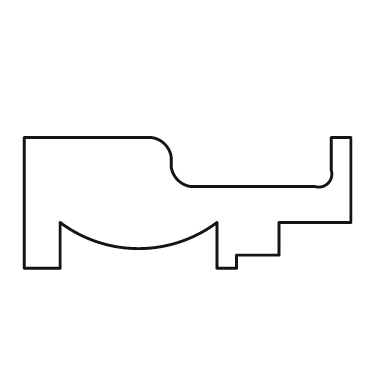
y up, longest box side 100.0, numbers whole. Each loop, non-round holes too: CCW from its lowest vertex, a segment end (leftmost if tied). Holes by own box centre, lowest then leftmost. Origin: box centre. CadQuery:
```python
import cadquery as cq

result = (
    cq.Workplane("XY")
    .moveTo(-50.0, -20.0)
    .lineTo(-39.0, -20.0)
    .lineTo(-39.0, -6.0)
    .threePointArc((-15.0, -14.0), (9.0, -6.0))
    .lineTo(9.0, -20.0)
    .lineTo(15.0, -20.0)
    .lineTo(15.0, -16.0)
    .lineTo(28.0, -16.0)
    .lineTo(28.0, -6.0)
    .lineTo(50.0, -6.0)
    .lineTo(50.0, 20.0)
    .lineTo(44.0, 20.0)
    .lineTo(44.0, 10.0)
    .threePointArc((43.0, 6.0), (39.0, 5.0))
    .lineTo(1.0, 5.0)
    .threePointArc((-3.0, 7.0), (-5.0, 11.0))
    .lineTo(-5.0, 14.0)
    .threePointArc((-7.0, 18.0), (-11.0, 20.0))
    .lineTo(-50.0, 20.0)
    .close()
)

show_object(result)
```